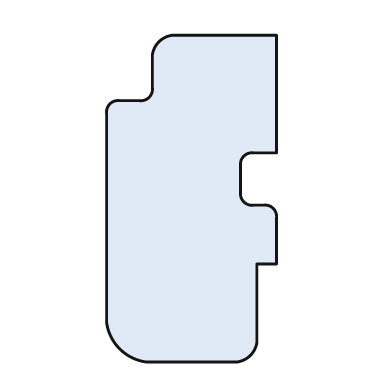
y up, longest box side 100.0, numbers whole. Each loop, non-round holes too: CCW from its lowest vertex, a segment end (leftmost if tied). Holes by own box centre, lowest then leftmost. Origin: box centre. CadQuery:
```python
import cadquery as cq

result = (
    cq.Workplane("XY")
    .moveTo(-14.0, -50.0)
    .lineTo(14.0, -50.0)
    .threePointArc((18.0, -48.0), (20.0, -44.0))
    .lineTo(20.0, -20.0)
    .lineTo(26.0, -20.0)
    .lineTo(26.0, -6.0)
    .threePointArc((25.0, -3.0), (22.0, -2.0))
    .lineTo(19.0, -2.0)
    .threePointArc((16.0, -1.0), (15.0, 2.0))
    .lineTo(15.0, 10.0)
    .threePointArc((16.0, 13.0), (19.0, 14.0))
    .lineTo(26.0, 14.0)
    .lineTo(26.0, 50.0)
    .lineTo(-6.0, 50.0)
    .threePointArc((-10.0, 48.0), (-12.0, 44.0))
    .lineTo(-12.0, 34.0)
    .threePointArc((-13.0, 31.0), (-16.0, 30.0))
    .lineTo(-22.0, 30.0)
    .threePointArc((-25.0, 29.0), (-26.0, 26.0))
    .lineTo(-26.0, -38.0)
    .threePointArc((-22.0, -46.0), (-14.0, -50.0))
    .close()
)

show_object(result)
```